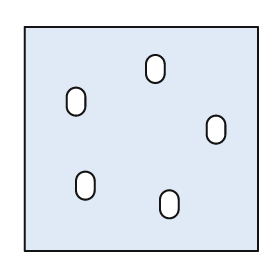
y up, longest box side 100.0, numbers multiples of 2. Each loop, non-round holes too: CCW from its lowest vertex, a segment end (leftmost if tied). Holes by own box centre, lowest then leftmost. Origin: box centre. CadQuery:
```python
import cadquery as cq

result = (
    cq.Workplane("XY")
    .moveTo(-50.0, -48.0)
    .lineTo(50.0, -48.0)
    .lineTo(50.0, 48.0)
    .lineTo(-50.0, 48.0)
    .close()
    .moveTo(8.0, -30.0)
    .threePointArc((12.0, -34.0), (16.0, -30.0))
    .lineTo(16.0, -26.0)
    .threePointArc((12.0, -22.0), (8.0, -26.0))
    .close()
    .moveTo(-28.0, -22.0)
    .threePointArc((-24.0, -26.0), (-20.0, -22.0))
    .lineTo(-20.0, -18.0)
    .threePointArc((-24.0, -14.0), (-28.0, -18.0))
    .close()
    .moveTo(28.0, 2.0)
    .threePointArc((32.0, -2.0), (36.0, 2.0))
    .lineTo(36.0, 6.0)
    .threePointArc((32.0, 10.0), (28.0, 6.0))
    .close()
    .moveTo(-32.0, 14.0)
    .threePointArc((-28.0, 10.0), (-24.0, 14.0))
    .lineTo(-24.0, 18.0)
    .threePointArc((-28.0, 22.0), (-32.0, 18.0))
    .close()
    .moveTo(2.0, 28.0)
    .threePointArc((6.0, 24.0), (10.0, 28.0))
    .lineTo(10.0, 32.0)
    .threePointArc((6.0, 36.0), (2.0, 32.0))
    .close()
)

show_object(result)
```